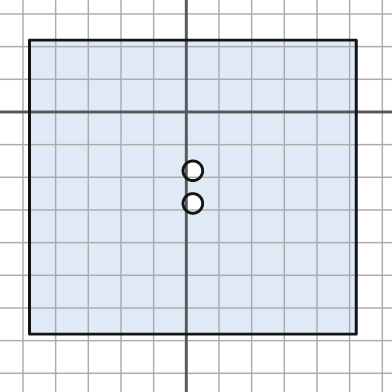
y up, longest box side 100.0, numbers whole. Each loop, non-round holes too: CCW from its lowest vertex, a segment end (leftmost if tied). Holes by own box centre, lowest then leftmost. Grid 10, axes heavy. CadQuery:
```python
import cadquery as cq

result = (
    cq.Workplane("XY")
    .moveTo(-48.0, -68.0)
    .lineTo(52.0, -68.0)
    .lineTo(52.0, 22.0)
    .lineTo(-48.0, 22.0)
    .close()
    .moveTo(2.0, -28.0)
    .circle(3.0)
    .moveTo(2.0, -18.0)
    .circle(3.0)
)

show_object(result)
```